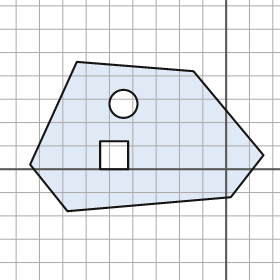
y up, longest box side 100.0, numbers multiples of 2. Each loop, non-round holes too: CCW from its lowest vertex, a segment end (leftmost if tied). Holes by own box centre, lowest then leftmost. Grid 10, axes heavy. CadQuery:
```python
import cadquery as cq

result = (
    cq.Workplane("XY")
    .moveTo(-68.0, -18.0)
    .lineTo(2.0, -12.0)
    .lineTo(16.0, 6.0)
    .lineTo(-14.0, 42.0)
    .lineTo(-64.0, 46.0)
    .lineTo(-84.0, 2.0)
    .close()
    .moveTo(-54.0, 0.0)
    .lineTo(-42.0, 0.0)
    .lineTo(-42.0, 12.0)
    .lineTo(-54.0, 12.0)
    .close()
    .moveTo(-44.0, 28.0)
    .circle(6.0)
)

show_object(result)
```